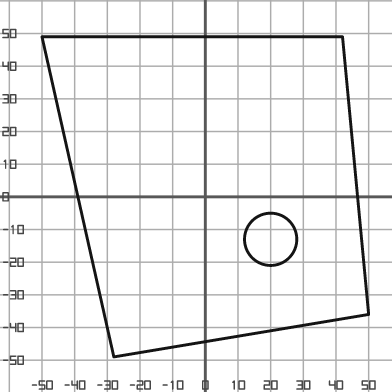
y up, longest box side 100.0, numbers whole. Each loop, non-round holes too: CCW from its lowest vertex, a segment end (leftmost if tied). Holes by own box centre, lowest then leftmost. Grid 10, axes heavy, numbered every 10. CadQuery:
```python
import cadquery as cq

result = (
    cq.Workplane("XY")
    .moveTo(-28.0, -49.0)
    .lineTo(50.0, -36.0)
    .lineTo(42.0, 49.0)
    .lineTo(-50.0, 49.0)
    .close()
    .moveTo(20.0, -13.0)
    .circle(8.0)
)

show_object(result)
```